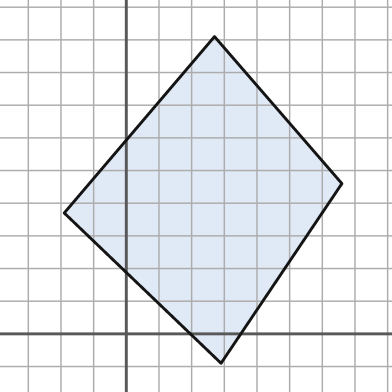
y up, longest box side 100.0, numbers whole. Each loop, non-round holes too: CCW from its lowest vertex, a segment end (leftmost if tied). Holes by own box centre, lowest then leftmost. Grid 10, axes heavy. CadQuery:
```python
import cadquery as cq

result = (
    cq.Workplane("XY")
    .moveTo(29.0, -9.0)
    .lineTo(66.0, 46.0)
    .lineTo(27.0, 91.0)
    .lineTo(-19.0, 37.0)
    .close()
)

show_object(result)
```